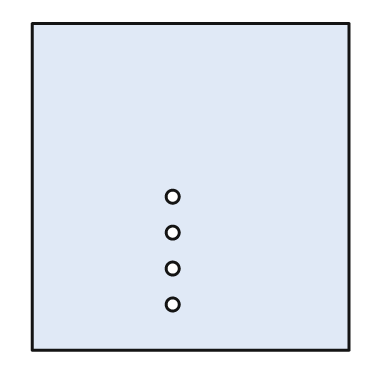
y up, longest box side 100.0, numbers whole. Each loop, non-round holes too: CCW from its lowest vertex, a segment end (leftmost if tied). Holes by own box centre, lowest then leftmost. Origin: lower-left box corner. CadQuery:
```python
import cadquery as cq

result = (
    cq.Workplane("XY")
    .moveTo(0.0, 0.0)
    .lineTo(97.0, 0.0)
    .lineTo(97.0, 100.0)
    .lineTo(0.0, 100.0)
    .close()
    .moveTo(43.0, 14.0)
    .circle(2.0)
    .moveTo(43.0, 25.0)
    .circle(2.0)
    .moveTo(43.0, 36.0)
    .circle(2.0)
    .moveTo(43.0, 47.0)
    .circle(2.0)
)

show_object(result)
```